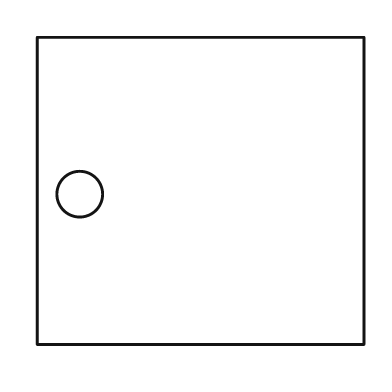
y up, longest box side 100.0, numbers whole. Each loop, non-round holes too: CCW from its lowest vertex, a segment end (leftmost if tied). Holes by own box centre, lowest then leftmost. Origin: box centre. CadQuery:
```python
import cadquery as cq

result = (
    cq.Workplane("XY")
    .moveTo(-50.0, -47.0)
    .lineTo(50.0, -47.0)
    .lineTo(50.0, 47.0)
    .lineTo(-50.0, 47.0)
    .close()
    .moveTo(-37.0, -1.0)
    .circle(7.0)
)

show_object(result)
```